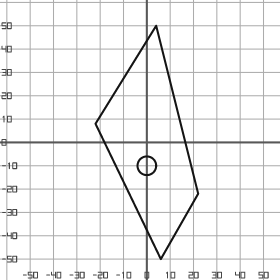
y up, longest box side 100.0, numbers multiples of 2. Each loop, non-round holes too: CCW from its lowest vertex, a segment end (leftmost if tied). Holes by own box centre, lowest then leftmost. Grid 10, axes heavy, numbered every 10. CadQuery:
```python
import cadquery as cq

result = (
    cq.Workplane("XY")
    .moveTo(6.0, -50.0)
    .lineTo(22.0, -22.0)
    .lineTo(4.0, 50.0)
    .lineTo(-22.0, 8.0)
    .close()
    .moveTo(0.0, -10.0)
    .circle(4.0)
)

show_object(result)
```